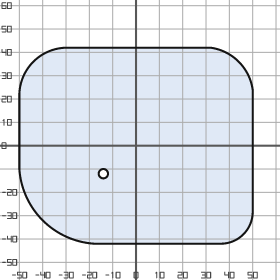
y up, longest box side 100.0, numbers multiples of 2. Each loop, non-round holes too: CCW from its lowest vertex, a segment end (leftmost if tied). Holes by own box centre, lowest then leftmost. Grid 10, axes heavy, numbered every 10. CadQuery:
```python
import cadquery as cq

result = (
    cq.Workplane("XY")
    .moveTo(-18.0, -42.0)
    .lineTo(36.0, -42.0)
    .threePointArc((46.0, -38.0), (50.0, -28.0))
    .lineTo(50.0, 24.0)
    .threePointArc((44.0, 36.0), (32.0, 42.0))
    .lineTo(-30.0, 42.0)
    .threePointArc((-44.0, 36.0), (-50.0, 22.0))
    .lineTo(-50.0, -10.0)
    .threePointArc((-40.0, -32.0), (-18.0, -42.0))
    .close()
    .moveTo(-14.0, -12.0)
    .circle(2.0)
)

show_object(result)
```